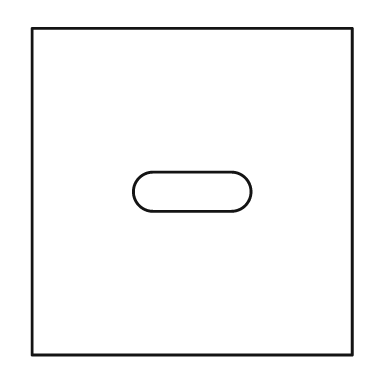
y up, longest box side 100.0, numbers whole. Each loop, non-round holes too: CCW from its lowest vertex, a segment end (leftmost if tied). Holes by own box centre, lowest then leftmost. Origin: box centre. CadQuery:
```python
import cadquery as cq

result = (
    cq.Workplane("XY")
    .moveTo(-49.0, -50.0)
    .lineTo(49.0, -50.0)
    .lineTo(49.0, 50.0)
    .lineTo(-49.0, 50.0)
    .close()
    .moveTo(-12.0, -6.0)
    .lineTo(12.0, -6.0)
    .threePointArc((18.0, 0.0), (12.0, 6.0))
    .lineTo(-12.0, 6.0)
    .threePointArc((-18.0, 0.0), (-12.0, -6.0))
    .close()
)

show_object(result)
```